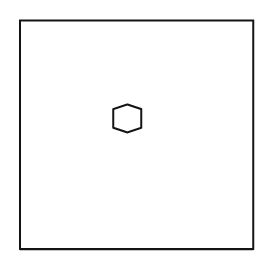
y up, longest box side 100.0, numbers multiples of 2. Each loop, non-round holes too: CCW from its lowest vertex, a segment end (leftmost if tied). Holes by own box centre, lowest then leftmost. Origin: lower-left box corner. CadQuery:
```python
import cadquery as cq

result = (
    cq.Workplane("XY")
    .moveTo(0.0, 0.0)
    .lineTo(100.0, 0.0)
    .lineTo(100.0, 98.0)
    .lineTo(0.0, 98.0)
    .close()
    .moveTo(46.0, 50.0)
    .lineTo(52.0, 52.0)
    .lineTo(52.0, 60.0)
    .lineTo(46.0, 62.0)
    .lineTo(40.0, 60.0)
    .lineTo(40.0, 52.0)
    .close()
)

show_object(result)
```